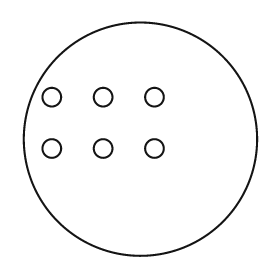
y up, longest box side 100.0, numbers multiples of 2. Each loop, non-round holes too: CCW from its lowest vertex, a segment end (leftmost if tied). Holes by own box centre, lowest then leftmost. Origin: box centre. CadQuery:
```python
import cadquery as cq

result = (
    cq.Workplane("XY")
    .moveTo(0.0, 0.0)
    .circle(50.0)
    .moveTo(-38.0, -4.0)
    .circle(4.0)
    .moveTo(-16.0, -4.0)
    .circle(4.0)
    .moveTo(6.0, -4.0)
    .circle(4.0)
    .moveTo(-38.0, 18.0)
    .circle(4.0)
    .moveTo(-16.0, 18.0)
    .circle(4.0)
    .moveTo(6.0, 18.0)
    .circle(4.0)
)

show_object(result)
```